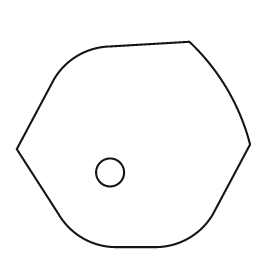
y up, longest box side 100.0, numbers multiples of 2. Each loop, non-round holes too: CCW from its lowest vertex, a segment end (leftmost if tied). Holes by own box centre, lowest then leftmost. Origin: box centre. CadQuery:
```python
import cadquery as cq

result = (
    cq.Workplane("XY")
    .moveTo(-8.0, -44.0)
    .lineTo(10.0, -44.0)
    .threePointArc((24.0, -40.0), (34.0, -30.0))
    .lineTo(50.0, 0.0)
    .threePointArc((40.0, 24.0), (24.0, 44.0))
    .lineTo(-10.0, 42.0)
    .threePointArc((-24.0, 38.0), (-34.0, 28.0))
    .lineTo(-50.0, -2.0)
    .lineTo(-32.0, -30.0)
    .threePointArc((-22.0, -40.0), (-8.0, -44.0))
    .close()
    .moveTo(-10.0, -12.0)
    .circle(6.0)
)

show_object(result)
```